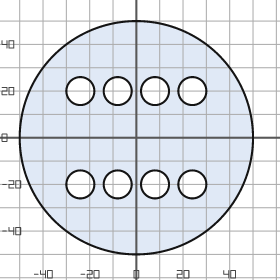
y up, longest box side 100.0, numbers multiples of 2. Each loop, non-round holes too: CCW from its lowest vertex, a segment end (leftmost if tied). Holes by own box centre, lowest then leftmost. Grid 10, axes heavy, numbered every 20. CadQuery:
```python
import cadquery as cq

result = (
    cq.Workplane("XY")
    .moveTo(0.0, 0.0)
    .circle(50.0)
    .moveTo(-24.0, -20.0)
    .circle(6.0)
    .moveTo(-8.0, -20.0)
    .circle(6.0)
    .moveTo(8.0, -20.0)
    .circle(6.0)
    .moveTo(24.0, -20.0)
    .circle(6.0)
    .moveTo(-24.0, 20.0)
    .circle(6.0)
    .moveTo(-8.0, 20.0)
    .circle(6.0)
    .moveTo(8.0, 20.0)
    .circle(6.0)
    .moveTo(24.0, 20.0)
    .circle(6.0)
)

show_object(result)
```